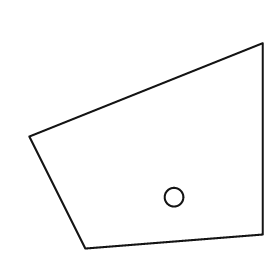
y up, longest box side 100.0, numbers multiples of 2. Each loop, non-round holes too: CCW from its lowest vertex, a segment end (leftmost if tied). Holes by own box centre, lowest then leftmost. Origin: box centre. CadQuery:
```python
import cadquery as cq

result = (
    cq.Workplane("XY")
    .moveTo(-26.0, -44.0)
    .lineTo(50.0, -38.0)
    .lineTo(50.0, 44.0)
    .lineTo(-50.0, 4.0)
    .close()
    .moveTo(12.0, -22.0)
    .circle(4.0)
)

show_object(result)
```